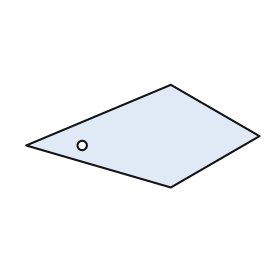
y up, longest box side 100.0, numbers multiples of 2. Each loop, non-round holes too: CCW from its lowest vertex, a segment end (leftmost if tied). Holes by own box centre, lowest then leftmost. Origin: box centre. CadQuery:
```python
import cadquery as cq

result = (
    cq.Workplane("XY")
    .moveTo(12.0, -22.0)
    .lineTo(50.0, 0.0)
    .lineTo(12.0, 22.0)
    .lineTo(-50.0, -4.0)
    .close()
    .moveTo(-26.0, -4.0)
    .circle(2.0)
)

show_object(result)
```